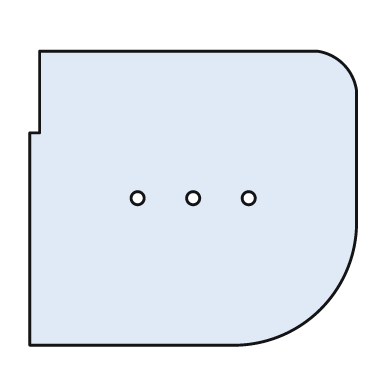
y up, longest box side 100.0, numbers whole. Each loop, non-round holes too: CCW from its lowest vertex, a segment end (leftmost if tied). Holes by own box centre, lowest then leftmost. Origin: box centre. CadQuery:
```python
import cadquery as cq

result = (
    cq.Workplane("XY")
    .moveTo(-50.0, -45.0)
    .lineTo(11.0, -45.0)
    .threePointArc((39.0, -34.0), (50.0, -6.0))
    .lineTo(50.0, 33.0)
    .threePointArc((46.0, 41.0), (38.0, 45.0))
    .lineTo(-47.0, 45.0)
    .lineTo(-47.0, 20.0)
    .lineTo(-50.0, 20.0)
    .close()
    .moveTo(-17.0, 0.0)
    .circle(2.0)
    .moveTo(0.0, 0.0)
    .circle(2.0)
    .moveTo(17.0, 0.0)
    .circle(2.0)
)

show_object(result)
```